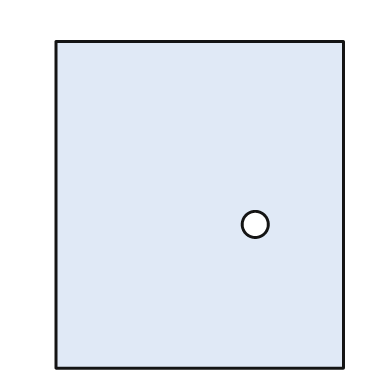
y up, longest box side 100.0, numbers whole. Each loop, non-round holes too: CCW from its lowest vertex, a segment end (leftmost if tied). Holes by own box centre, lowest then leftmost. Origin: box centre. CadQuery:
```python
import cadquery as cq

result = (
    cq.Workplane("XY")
    .moveTo(-44.0, -50.0)
    .lineTo(44.0, -50.0)
    .lineTo(44.0, 50.0)
    .lineTo(-44.0, 50.0)
    .close()
    .moveTo(17.0, -6.0)
    .circle(4.0)
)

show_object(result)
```